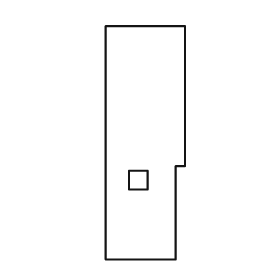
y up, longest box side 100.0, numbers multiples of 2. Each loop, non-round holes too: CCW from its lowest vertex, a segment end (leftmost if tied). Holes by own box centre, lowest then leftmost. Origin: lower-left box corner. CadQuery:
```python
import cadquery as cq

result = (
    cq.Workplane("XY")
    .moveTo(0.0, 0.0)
    .lineTo(30.0, 0.0)
    .lineTo(30.0, 40.0)
    .lineTo(34.0, 40.0)
    .lineTo(34.0, 100.0)
    .lineTo(0.0, 100.0)
    .close()
    .moveTo(10.0, 30.0)
    .lineTo(18.0, 30.0)
    .lineTo(18.0, 38.0)
    .lineTo(10.0, 38.0)
    .close()
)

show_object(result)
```